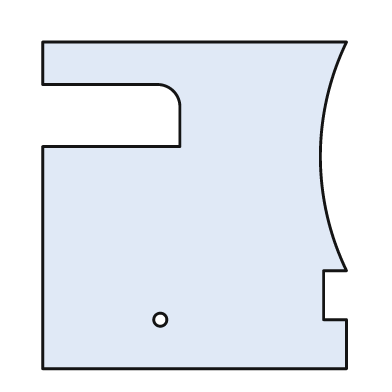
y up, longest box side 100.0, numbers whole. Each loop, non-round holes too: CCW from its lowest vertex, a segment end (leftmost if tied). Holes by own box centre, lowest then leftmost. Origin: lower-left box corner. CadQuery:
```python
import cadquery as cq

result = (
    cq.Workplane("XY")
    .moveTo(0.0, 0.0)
    .lineTo(93.0, 0.0)
    .lineTo(93.0, 15.0)
    .lineTo(86.0, 15.0)
    .lineTo(86.0, 30.0)
    .lineTo(93.0, 30.0)
    .threePointArc((85.0, 65.0), (93.0, 100.0))
    .lineTo(0.0, 100.0)
    .lineTo(0.0, 87.0)
    .lineTo(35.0, 87.0)
    .threePointArc((40.0, 85.0), (42.0, 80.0))
    .lineTo(42.0, 68.0)
    .lineTo(0.0, 68.0)
    .close()
    .moveTo(36.0, 15.0)
    .circle(2.0)
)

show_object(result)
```